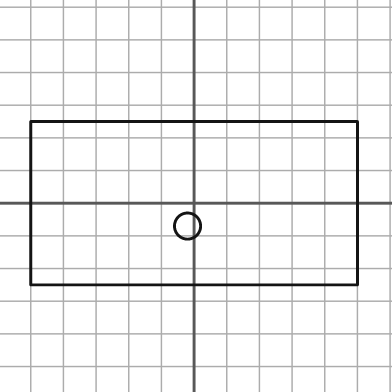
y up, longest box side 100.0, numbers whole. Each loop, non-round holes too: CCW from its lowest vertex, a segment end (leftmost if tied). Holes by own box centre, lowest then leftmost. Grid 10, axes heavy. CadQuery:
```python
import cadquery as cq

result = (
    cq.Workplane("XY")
    .moveTo(-50.0, -25.0)
    .lineTo(50.0, -25.0)
    .lineTo(50.0, 25.0)
    .lineTo(-50.0, 25.0)
    .close()
    .moveTo(-2.0, -7.0)
    .circle(4.0)
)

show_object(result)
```